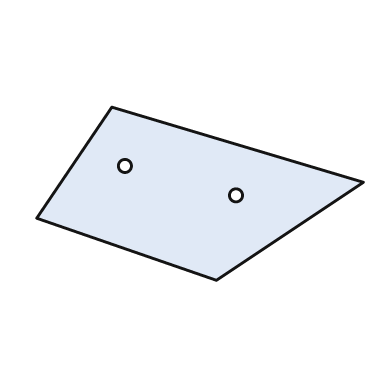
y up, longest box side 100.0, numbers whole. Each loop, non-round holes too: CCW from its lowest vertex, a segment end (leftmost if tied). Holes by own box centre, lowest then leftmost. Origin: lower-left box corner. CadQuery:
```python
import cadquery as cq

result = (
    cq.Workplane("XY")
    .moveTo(55.0, 0.0)
    .lineTo(100.0, 30.0)
    .lineTo(23.0, 53.0)
    .lineTo(0.0, 19.0)
    .close()
    .moveTo(61.0, 26.0)
    .circle(2.0)
    .moveTo(27.0, 35.0)
    .circle(2.0)
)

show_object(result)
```